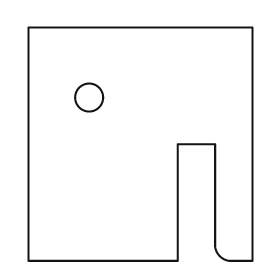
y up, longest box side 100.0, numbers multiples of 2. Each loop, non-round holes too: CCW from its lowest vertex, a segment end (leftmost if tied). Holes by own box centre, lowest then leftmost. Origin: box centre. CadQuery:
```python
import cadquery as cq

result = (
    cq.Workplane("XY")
    .moveTo(-48.0, -50.0)
    .lineTo(16.0, -50.0)
    .lineTo(16.0, 0.0)
    .lineTo(32.0, 0.0)
    .lineTo(32.0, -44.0)
    .threePointArc((34.0, -48.0), (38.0, -50.0))
    .lineTo(48.0, -50.0)
    .lineTo(48.0, 50.0)
    .lineTo(-48.0, 50.0)
    .close()
    .moveTo(-22.0, 20.0)
    .circle(6.0)
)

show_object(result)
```